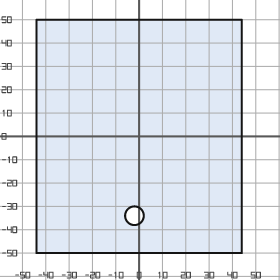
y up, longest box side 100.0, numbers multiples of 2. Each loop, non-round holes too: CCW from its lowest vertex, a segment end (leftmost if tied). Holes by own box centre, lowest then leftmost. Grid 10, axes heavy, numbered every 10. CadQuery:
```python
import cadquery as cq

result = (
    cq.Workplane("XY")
    .moveTo(-44.0, -50.0)
    .lineTo(44.0, -50.0)
    .lineTo(44.0, 50.0)
    .lineTo(-44.0, 50.0)
    .close()
    .moveTo(-2.0, -34.0)
    .circle(4.0)
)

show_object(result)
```